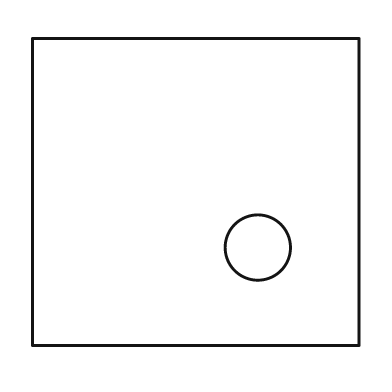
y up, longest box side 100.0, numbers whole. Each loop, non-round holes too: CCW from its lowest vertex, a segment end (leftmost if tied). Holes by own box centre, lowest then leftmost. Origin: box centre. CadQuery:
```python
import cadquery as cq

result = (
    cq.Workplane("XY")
    .moveTo(-50.0, -47.0)
    .lineTo(50.0, -47.0)
    .lineTo(50.0, 47.0)
    .lineTo(-50.0, 47.0)
    .close()
    .moveTo(19.0, -17.0)
    .circle(10.0)
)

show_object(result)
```